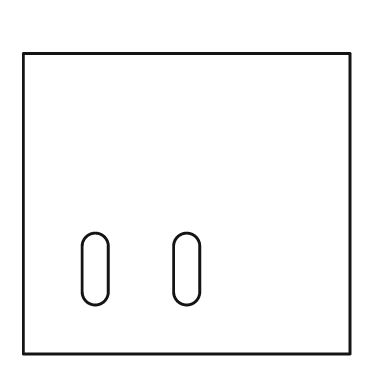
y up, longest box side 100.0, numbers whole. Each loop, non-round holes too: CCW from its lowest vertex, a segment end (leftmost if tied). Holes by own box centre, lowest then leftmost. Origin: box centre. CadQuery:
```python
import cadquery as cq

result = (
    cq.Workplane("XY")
    .moveTo(-50.0, -46.0)
    .lineTo(50.0, -46.0)
    .lineTo(50.0, 46.0)
    .lineTo(-50.0, 46.0)
    .close()
    .moveTo(-32.0, -27.0)
    .threePointArc((-28.0, -31.0), (-24.0, -27.0))
    .lineTo(-24.0, -13.0)
    .threePointArc((-28.0, -9.0), (-32.0, -13.0))
    .close()
    .moveTo(-4.0, -27.0)
    .threePointArc((0.0, -31.0), (4.0, -27.0))
    .lineTo(4.0, -13.0)
    .threePointArc((0.0, -9.0), (-4.0, -13.0))
    .close()
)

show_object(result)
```